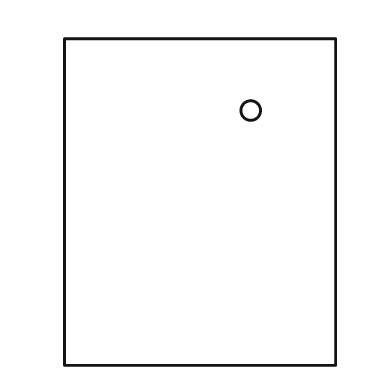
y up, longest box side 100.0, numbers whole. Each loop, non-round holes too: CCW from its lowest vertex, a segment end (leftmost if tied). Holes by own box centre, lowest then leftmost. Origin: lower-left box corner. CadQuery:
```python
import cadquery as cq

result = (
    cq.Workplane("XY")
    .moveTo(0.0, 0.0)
    .lineTo(83.0, 0.0)
    .lineTo(83.0, 100.0)
    .lineTo(0.0, 100.0)
    .close()
    .moveTo(57.0, 78.0)
    .circle(3.0)
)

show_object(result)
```